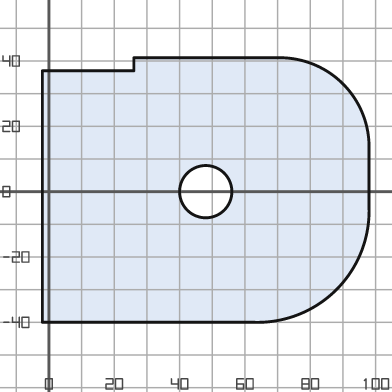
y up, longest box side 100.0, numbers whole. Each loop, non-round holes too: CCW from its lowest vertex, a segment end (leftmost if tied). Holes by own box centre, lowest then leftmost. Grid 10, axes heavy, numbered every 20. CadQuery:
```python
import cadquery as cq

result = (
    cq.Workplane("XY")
    .moveTo(-2.0, -40.0)
    .lineTo(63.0, -40.0)
    .threePointArc((88.0, -30.0), (98.0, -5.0))
    .lineTo(98.0, 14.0)
    .threePointArc((90.0, 33.0), (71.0, 41.0))
    .lineTo(26.0, 41.0)
    .lineTo(26.0, 37.0)
    .lineTo(-2.0, 37.0)
    .close()
    .moveTo(48.0, 0.0)
    .circle(8.0)
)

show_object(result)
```